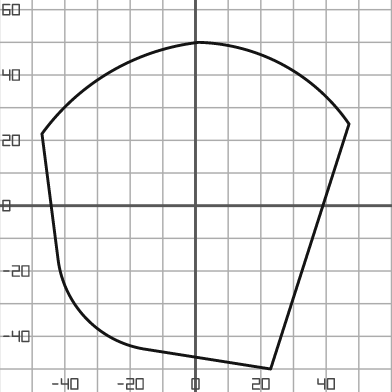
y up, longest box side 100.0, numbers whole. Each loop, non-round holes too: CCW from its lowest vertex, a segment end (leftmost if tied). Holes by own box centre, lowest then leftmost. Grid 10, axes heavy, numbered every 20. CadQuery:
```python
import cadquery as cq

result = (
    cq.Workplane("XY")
    .moveTo(23.0, -50.0)
    .lineTo(47.0, 25.0)
    .threePointArc((27.0, 43.0), (1.0, 50.0))
    .threePointArc((-26.0, 41.0), (-47.0, 22.0))
    .lineTo(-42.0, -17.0)
    .threePointArc((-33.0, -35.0), (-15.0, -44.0))
    .close()
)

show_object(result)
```